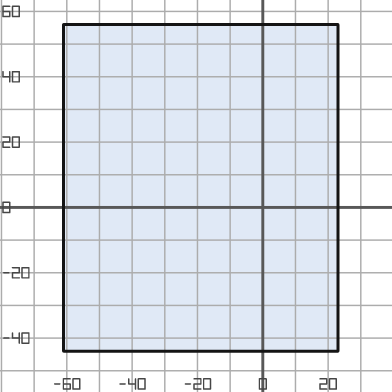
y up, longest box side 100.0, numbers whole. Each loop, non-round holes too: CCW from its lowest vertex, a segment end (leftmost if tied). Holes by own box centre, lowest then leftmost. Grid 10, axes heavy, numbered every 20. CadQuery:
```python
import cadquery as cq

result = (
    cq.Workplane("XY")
    .moveTo(-61.0, -44.0)
    .lineTo(23.0, -44.0)
    .lineTo(23.0, 56.0)
    .lineTo(-61.0, 56.0)
    .close()
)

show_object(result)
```